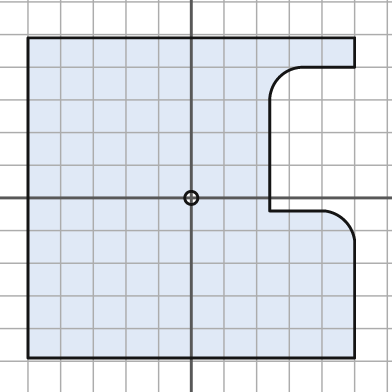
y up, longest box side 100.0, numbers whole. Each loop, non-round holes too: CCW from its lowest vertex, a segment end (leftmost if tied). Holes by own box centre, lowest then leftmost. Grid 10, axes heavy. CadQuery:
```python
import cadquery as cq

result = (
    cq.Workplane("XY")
    .moveTo(-50.0, -49.0)
    .lineTo(50.0, -49.0)
    .lineTo(50.0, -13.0)
    .threePointArc((47.0, -7.0), (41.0, -4.0))
    .lineTo(24.0, -4.0)
    .lineTo(24.0, 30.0)
    .threePointArc((27.0, 37.0), (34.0, 40.0))
    .lineTo(50.0, 40.0)
    .lineTo(50.0, 49.0)
    .lineTo(-50.0, 49.0)
    .close()
    .moveTo(0.0, 0.0)
    .circle(2.0)
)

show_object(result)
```